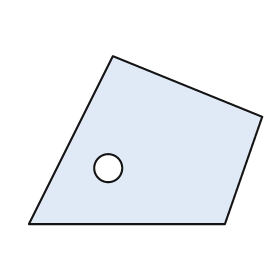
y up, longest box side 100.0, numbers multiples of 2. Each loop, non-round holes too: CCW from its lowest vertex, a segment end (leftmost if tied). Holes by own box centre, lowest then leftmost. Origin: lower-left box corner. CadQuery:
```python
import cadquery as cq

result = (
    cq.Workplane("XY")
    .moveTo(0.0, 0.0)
    .lineTo(84.0, 0.0)
    .lineTo(100.0, 46.0)
    .lineTo(36.0, 72.0)
    .close()
    .moveTo(34.0, 24.0)
    .circle(6.0)
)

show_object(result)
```